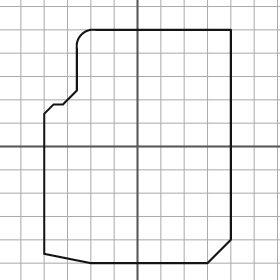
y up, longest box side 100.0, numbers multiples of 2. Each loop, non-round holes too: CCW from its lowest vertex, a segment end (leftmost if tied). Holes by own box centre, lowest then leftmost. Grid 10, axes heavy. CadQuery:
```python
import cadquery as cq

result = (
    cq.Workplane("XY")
    .moveTo(-20.0, -50.0)
    .lineTo(30.0, -50.0)
    .lineTo(40.0, -40.0)
    .lineTo(40.0, 50.0)
    .lineTo(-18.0, 50.0)
    .threePointArc((-24.0, 48.0), (-26.0, 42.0))
    .lineTo(-26.0, 24.0)
    .lineTo(-32.0, 18.0)
    .lineTo(-36.0, 18.0)
    .lineTo(-40.0, 14.0)
    .lineTo(-40.0, -46.0)
    .close()
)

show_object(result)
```